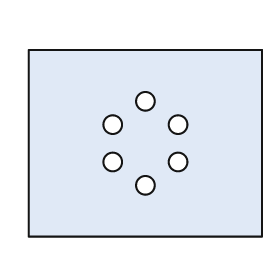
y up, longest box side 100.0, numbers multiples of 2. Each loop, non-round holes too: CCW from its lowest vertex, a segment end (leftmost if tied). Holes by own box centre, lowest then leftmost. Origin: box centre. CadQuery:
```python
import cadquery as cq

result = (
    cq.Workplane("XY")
    .moveTo(-50.0, -40.0)
    .lineTo(50.0, -40.0)
    .lineTo(50.0, 40.0)
    .lineTo(-50.0, 40.0)
    .close()
    .moveTo(0.0, -18.0)
    .circle(4.0)
    .moveTo(-14.0, -8.0)
    .circle(4.0)
    .moveTo(14.0, -8.0)
    .circle(4.0)
    .moveTo(-14.0, 8.0)
    .circle(4.0)
    .moveTo(14.0, 8.0)
    .circle(4.0)
    .moveTo(0.0, 18.0)
    .circle(4.0)
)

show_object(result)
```